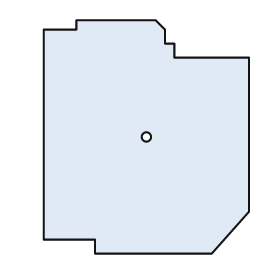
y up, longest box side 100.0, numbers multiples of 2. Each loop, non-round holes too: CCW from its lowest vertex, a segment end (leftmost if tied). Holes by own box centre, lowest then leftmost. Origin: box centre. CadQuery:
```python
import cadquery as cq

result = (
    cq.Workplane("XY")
    .moveTo(-22.0, -50.0)
    .lineTo(28.0, -50.0)
    .lineTo(44.0, -32.0)
    .lineTo(44.0, 34.0)
    .lineTo(12.0, 34.0)
    .lineTo(12.0, 40.0)
    .lineTo(8.0, 40.0)
    .lineTo(8.0, 46.0)
    .lineTo(4.0, 50.0)
    .lineTo(-30.0, 50.0)
    .lineTo(-30.0, 46.0)
    .lineTo(-44.0, 46.0)
    .lineTo(-44.0, -44.0)
    .lineTo(-22.0, -44.0)
    .close()
    .moveTo(0.0, 0.0)
    .circle(2.0)
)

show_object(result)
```